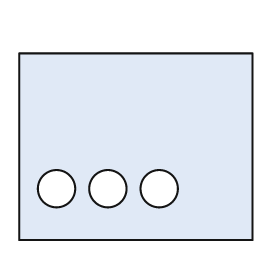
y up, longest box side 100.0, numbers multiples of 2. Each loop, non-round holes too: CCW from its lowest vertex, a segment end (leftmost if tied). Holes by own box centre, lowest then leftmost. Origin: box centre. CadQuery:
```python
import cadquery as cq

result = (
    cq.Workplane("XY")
    .moveTo(-50.0, -40.0)
    .lineTo(50.0, -40.0)
    .lineTo(50.0, 40.0)
    .lineTo(-50.0, 40.0)
    .close()
    .moveTo(-34.0, -18.0)
    .circle(8.0)
    .moveTo(-12.0, -18.0)
    .circle(8.0)
    .moveTo(10.0, -18.0)
    .circle(8.0)
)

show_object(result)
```